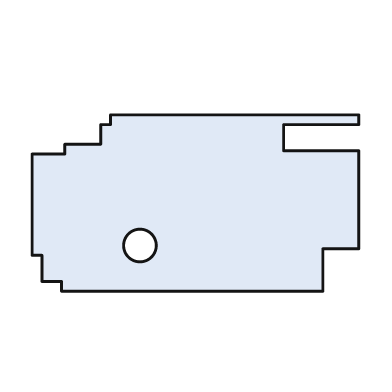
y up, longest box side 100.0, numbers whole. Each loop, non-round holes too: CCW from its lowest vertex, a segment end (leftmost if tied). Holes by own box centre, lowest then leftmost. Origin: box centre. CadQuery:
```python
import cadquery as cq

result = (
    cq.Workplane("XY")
    .moveTo(-41.0, -27.0)
    .lineTo(39.0, -27.0)
    .lineTo(39.0, -14.0)
    .lineTo(50.0, -14.0)
    .lineTo(50.0, 16.0)
    .lineTo(27.0, 16.0)
    .lineTo(27.0, 24.0)
    .lineTo(50.0, 24.0)
    .lineTo(50.0, 27.0)
    .lineTo(-26.0, 27.0)
    .lineTo(-26.0, 24.0)
    .lineTo(-29.0, 24.0)
    .lineTo(-29.0, 18.0)
    .lineTo(-40.0, 18.0)
    .lineTo(-40.0, 15.0)
    .lineTo(-50.0, 15.0)
    .lineTo(-50.0, -16.0)
    .lineTo(-47.0, -16.0)
    .lineTo(-47.0, -24.0)
    .lineTo(-41.0, -24.0)
    .close()
    .moveTo(-17.0, -13.0)
    .circle(5.0)
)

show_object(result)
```